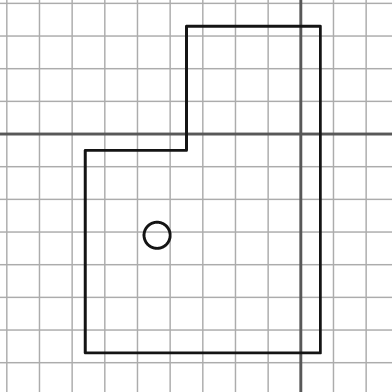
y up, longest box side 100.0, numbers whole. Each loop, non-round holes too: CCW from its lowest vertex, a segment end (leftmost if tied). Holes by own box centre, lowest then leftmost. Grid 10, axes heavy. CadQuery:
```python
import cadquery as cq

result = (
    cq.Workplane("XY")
    .moveTo(-66.0, -67.0)
    .lineTo(6.0, -67.0)
    .lineTo(6.0, 33.0)
    .lineTo(-35.0, 33.0)
    .lineTo(-35.0, -5.0)
    .lineTo(-66.0, -5.0)
    .close()
    .moveTo(-44.0, -31.0)
    .circle(4.0)
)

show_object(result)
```